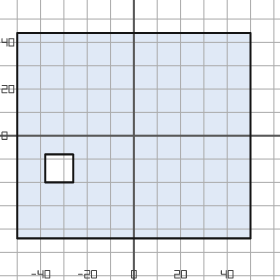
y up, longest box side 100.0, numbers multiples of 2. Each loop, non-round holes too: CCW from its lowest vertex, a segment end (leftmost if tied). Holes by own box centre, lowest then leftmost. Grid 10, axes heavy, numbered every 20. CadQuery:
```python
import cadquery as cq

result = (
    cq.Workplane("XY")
    .moveTo(-50.0, -44.0)
    .lineTo(50.0, -44.0)
    .lineTo(50.0, 44.0)
    .lineTo(-50.0, 44.0)
    .close()
    .moveTo(-38.0, -20.0)
    .lineTo(-26.0, -20.0)
    .lineTo(-26.0, -8.0)
    .lineTo(-38.0, -8.0)
    .close()
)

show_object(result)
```